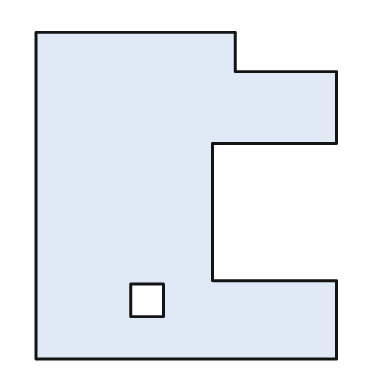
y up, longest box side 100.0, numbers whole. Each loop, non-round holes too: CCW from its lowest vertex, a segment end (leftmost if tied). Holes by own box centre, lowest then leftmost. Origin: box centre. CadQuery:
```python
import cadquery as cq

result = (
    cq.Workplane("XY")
    .moveTo(-46.0, -50.0)
    .lineTo(46.0, -50.0)
    .lineTo(46.0, -26.0)
    .lineTo(8.0, -26.0)
    .lineTo(8.0, 16.0)
    .lineTo(46.0, 16.0)
    .lineTo(46.0, 38.0)
    .lineTo(15.0, 38.0)
    .lineTo(15.0, 50.0)
    .lineTo(-46.0, 50.0)
    .close()
    .moveTo(-17.0, -37.0)
    .lineTo(-7.0, -37.0)
    .lineTo(-7.0, -27.0)
    .lineTo(-17.0, -27.0)
    .close()
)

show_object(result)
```